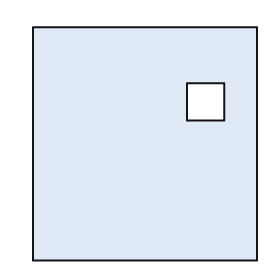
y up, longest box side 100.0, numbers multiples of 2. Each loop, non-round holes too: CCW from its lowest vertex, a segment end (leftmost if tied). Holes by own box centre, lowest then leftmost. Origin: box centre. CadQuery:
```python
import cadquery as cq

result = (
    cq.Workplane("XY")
    .moveTo(-48.0, -50.0)
    .lineTo(48.0, -50.0)
    .lineTo(48.0, 50.0)
    .lineTo(-48.0, 50.0)
    .close()
    .moveTo(18.0, 10.0)
    .lineTo(34.0, 10.0)
    .lineTo(34.0, 26.0)
    .lineTo(18.0, 26.0)
    .close()
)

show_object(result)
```